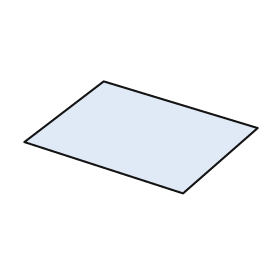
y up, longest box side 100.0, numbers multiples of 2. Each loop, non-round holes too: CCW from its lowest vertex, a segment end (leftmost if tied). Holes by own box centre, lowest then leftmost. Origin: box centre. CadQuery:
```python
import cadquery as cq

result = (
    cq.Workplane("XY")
    .moveTo(18.0, -24.0)
    .lineTo(50.0, 4.0)
    .lineTo(-16.0, 24.0)
    .lineTo(-50.0, -2.0)
    .close()
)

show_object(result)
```